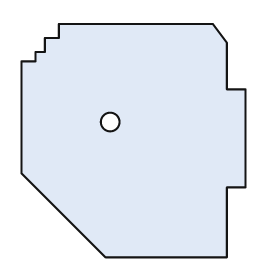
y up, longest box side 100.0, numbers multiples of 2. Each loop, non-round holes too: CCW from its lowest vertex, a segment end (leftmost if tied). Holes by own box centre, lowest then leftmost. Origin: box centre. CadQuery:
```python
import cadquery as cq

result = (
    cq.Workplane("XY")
    .moveTo(-12.0, -50.0)
    .lineTo(40.0, -50.0)
    .lineTo(40.0, -20.0)
    .lineTo(48.0, -20.0)
    .lineTo(48.0, 22.0)
    .lineTo(40.0, 22.0)
    .lineTo(40.0, 42.0)
    .lineTo(34.0, 50.0)
    .lineTo(-32.0, 50.0)
    .lineTo(-32.0, 44.0)
    .lineTo(-38.0, 44.0)
    .lineTo(-38.0, 38.0)
    .lineTo(-42.0, 38.0)
    .lineTo(-42.0, 34.0)
    .lineTo(-48.0, 34.0)
    .lineTo(-48.0, -14.0)
    .close()
    .moveTo(-10.0, 8.0)
    .circle(4.0)
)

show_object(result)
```